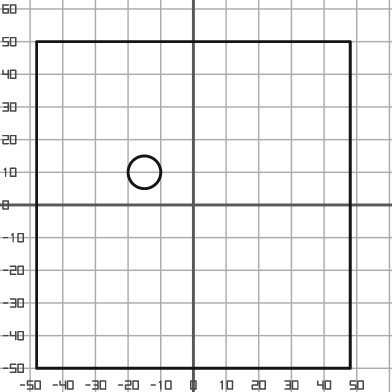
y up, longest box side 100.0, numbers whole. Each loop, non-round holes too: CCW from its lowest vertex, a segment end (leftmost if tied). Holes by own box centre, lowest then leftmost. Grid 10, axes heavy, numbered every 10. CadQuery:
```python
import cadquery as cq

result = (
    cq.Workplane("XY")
    .moveTo(-48.0, -50.0)
    .lineTo(48.0, -50.0)
    .lineTo(48.0, 50.0)
    .lineTo(-48.0, 50.0)
    .close()
    .moveTo(-15.0, 10.0)
    .circle(5.0)
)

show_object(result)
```